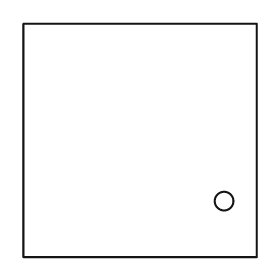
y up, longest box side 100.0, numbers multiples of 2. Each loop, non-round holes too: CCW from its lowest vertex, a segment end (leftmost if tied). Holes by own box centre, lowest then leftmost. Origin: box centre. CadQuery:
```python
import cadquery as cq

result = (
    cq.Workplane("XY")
    .moveTo(-50.0, -50.0)
    .lineTo(50.0, -50.0)
    .lineTo(50.0, 50.0)
    .lineTo(-50.0, 50.0)
    .close()
    .moveTo(36.0, -26.0)
    .circle(4.0)
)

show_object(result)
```